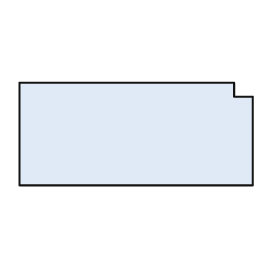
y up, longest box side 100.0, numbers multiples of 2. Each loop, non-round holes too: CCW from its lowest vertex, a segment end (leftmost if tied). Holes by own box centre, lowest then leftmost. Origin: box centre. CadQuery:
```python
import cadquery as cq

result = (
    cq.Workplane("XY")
    .moveTo(-50.0, -22.0)
    .lineTo(50.0, -22.0)
    .lineTo(50.0, 16.0)
    .lineTo(42.0, 16.0)
    .lineTo(42.0, 22.0)
    .lineTo(-50.0, 22.0)
    .close()
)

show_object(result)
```